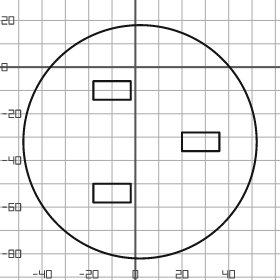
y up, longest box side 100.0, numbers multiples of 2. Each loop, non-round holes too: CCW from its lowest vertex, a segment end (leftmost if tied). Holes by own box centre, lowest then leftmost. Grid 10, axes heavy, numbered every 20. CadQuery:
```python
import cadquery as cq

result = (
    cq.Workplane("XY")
    .moveTo(2.0, -32.0)
    .circle(50.0)
    .moveTo(-18.0, -58.0)
    .lineTo(-2.0, -58.0)
    .lineTo(-2.0, -50.0)
    .lineTo(-18.0, -50.0)
    .close()
    .moveTo(20.0, -36.0)
    .lineTo(36.0, -36.0)
    .lineTo(36.0, -28.0)
    .lineTo(20.0, -28.0)
    .close()
    .moveTo(-18.0, -14.0)
    .lineTo(-2.0, -14.0)
    .lineTo(-2.0, -6.0)
    .lineTo(-18.0, -6.0)
    .close()
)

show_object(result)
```